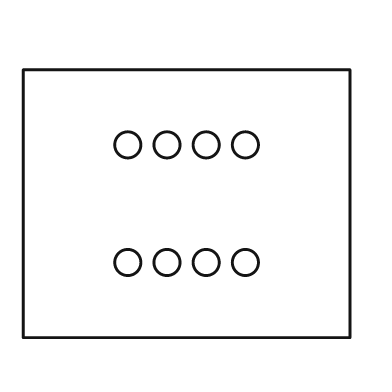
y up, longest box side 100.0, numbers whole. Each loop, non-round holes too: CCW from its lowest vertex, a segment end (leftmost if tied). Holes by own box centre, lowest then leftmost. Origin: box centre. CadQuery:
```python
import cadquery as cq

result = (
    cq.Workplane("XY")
    .moveTo(-50.0, -41.0)
    .lineTo(50.0, -41.0)
    .lineTo(50.0, 41.0)
    .lineTo(-50.0, 41.0)
    .close()
    .moveTo(-18.0, -18.0)
    .circle(4.0)
    .moveTo(-6.0, -18.0)
    .circle(4.0)
    .moveTo(6.0, -18.0)
    .circle(4.0)
    .moveTo(18.0, -18.0)
    .circle(4.0)
    .moveTo(-18.0, 18.0)
    .circle(4.0)
    .moveTo(-6.0, 18.0)
    .circle(4.0)
    .moveTo(6.0, 18.0)
    .circle(4.0)
    .moveTo(18.0, 18.0)
    .circle(4.0)
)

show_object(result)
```